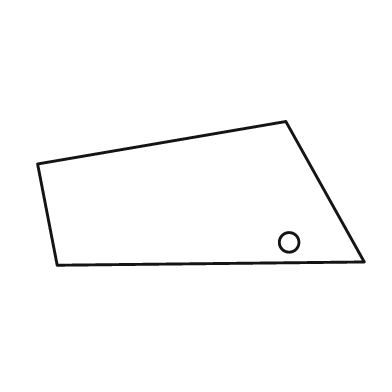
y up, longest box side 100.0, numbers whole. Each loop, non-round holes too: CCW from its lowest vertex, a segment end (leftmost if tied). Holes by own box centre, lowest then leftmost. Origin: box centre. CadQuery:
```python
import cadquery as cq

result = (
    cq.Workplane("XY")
    .moveTo(-44.0, -22.0)
    .lineTo(50.0, -21.0)
    .lineTo(26.0, 22.0)
    .lineTo(-50.0, 9.0)
    .close()
    .moveTo(27.0, -15.0)
    .circle(3.0)
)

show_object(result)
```